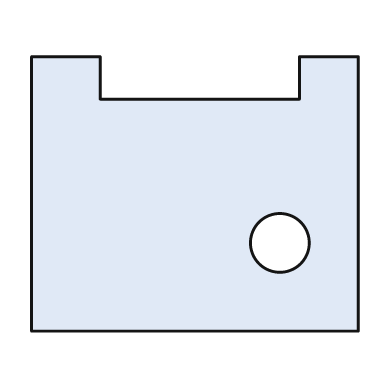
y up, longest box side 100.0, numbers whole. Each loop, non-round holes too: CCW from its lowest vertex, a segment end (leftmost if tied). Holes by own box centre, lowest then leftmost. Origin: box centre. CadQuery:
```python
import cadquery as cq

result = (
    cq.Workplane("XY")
    .moveTo(-50.0, -42.0)
    .lineTo(50.0, -42.0)
    .lineTo(50.0, 42.0)
    .lineTo(32.0, 42.0)
    .lineTo(32.0, 29.0)
    .lineTo(-29.0, 29.0)
    .lineTo(-29.0, 42.0)
    .lineTo(-50.0, 42.0)
    .close()
    .moveTo(26.0, -15.0)
    .circle(9.0)
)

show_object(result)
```